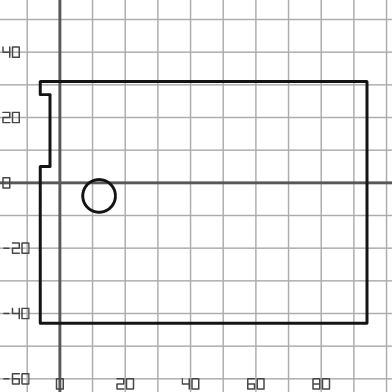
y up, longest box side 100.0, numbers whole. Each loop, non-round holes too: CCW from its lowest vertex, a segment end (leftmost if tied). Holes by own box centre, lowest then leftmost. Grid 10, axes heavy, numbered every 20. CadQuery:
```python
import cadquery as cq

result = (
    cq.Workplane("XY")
    .moveTo(-6.0, -43.0)
    .lineTo(94.0, -43.0)
    .lineTo(94.0, 31.0)
    .lineTo(-6.0, 31.0)
    .lineTo(-6.0, 27.0)
    .lineTo(-3.0, 27.0)
    .lineTo(-3.0, 5.0)
    .lineTo(-6.0, 5.0)
    .close()
    .moveTo(12.0, -4.0)
    .circle(5.0)
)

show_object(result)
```